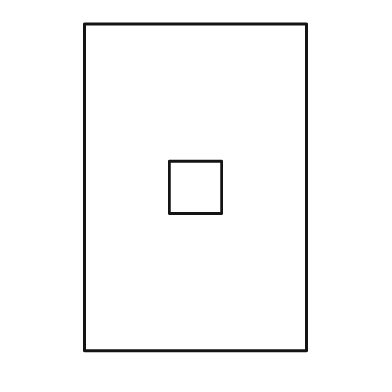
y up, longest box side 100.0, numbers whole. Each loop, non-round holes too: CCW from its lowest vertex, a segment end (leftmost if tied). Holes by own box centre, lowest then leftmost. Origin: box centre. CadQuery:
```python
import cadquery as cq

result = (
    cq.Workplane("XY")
    .moveTo(-34.0, -50.0)
    .lineTo(34.0, -50.0)
    .lineTo(34.0, 50.0)
    .lineTo(-34.0, 50.0)
    .close()
    .moveTo(-8.0, -8.0)
    .lineTo(8.0, -8.0)
    .lineTo(8.0, 8.0)
    .lineTo(-8.0, 8.0)
    .close()
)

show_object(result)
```